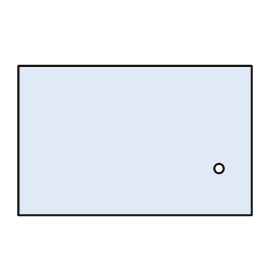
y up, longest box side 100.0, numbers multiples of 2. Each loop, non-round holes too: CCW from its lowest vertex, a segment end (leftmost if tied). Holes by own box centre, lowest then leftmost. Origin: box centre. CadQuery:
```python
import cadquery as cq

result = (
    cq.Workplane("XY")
    .moveTo(-50.0, -32.0)
    .lineTo(50.0, -32.0)
    .lineTo(50.0, 32.0)
    .lineTo(-50.0, 32.0)
    .close()
    .moveTo(36.0, -12.0)
    .circle(2.0)
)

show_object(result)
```